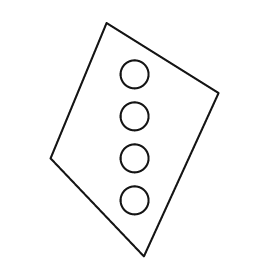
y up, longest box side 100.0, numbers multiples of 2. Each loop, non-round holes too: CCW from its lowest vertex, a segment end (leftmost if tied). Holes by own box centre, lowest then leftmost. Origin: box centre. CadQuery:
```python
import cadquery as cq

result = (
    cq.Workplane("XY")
    .moveTo(4.0, -50.0)
    .lineTo(36.0, 20.0)
    .lineTo(-12.0, 50.0)
    .lineTo(-36.0, -8.0)
    .close()
    .moveTo(0.0, -26.0)
    .circle(6.0)
    .moveTo(0.0, -8.0)
    .circle(6.0)
    .moveTo(0.0, 10.0)
    .circle(6.0)
    .moveTo(0.0, 28.0)
    .circle(6.0)
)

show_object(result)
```